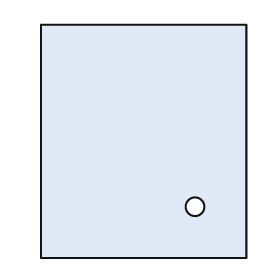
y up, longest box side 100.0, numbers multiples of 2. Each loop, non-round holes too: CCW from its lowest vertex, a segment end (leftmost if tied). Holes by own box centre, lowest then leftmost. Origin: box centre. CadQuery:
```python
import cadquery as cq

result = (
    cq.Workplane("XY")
    .moveTo(-44.0, -50.0)
    .lineTo(44.0, -50.0)
    .lineTo(44.0, 50.0)
    .lineTo(-44.0, 50.0)
    .close()
    .moveTo(22.0, -28.0)
    .circle(4.0)
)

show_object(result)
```